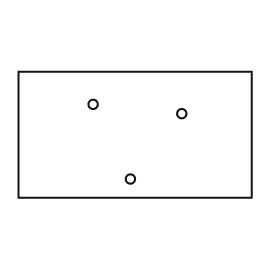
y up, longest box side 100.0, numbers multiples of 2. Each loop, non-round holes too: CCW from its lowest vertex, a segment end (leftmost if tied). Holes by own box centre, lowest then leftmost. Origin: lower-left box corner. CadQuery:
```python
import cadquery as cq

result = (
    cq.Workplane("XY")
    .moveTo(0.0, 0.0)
    .lineTo(100.0, 0.0)
    .lineTo(100.0, 54.0)
    .lineTo(0.0, 54.0)
    .close()
    .moveTo(48.0, 8.0)
    .circle(2.0)
    .moveTo(70.0, 36.0)
    .circle(2.0)
    .moveTo(32.0, 40.0)
    .circle(2.0)
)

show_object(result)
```